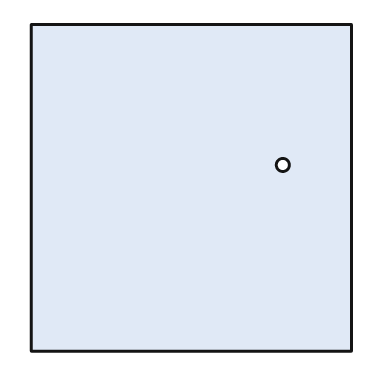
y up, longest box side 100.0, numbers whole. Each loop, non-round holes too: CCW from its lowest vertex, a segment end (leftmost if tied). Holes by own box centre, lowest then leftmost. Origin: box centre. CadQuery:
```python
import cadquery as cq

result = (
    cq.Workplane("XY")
    .moveTo(-49.0, -50.0)
    .lineTo(49.0, -50.0)
    .lineTo(49.0, 50.0)
    .lineTo(-49.0, 50.0)
    .close()
    .moveTo(28.0, 7.0)
    .circle(2.0)
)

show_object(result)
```